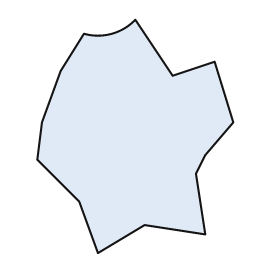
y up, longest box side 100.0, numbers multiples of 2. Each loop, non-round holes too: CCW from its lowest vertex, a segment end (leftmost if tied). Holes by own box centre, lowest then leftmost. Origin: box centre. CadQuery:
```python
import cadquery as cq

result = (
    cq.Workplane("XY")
    .moveTo(-16.0, -50.0)
    .lineTo(4.0, -38.0)
    .lineTo(30.0, -42.0)
    .lineTo(26.0, -16.0)
    .lineTo(30.0, -8.0)
    .lineTo(42.0, 6.0)
    .lineTo(34.0, 32.0)
    .lineTo(16.0, 26.0)
    .lineTo(0.0, 50.0)
    .threePointArc((-10.0, 44.0), (-22.0, 44.0))
    .lineTo(-32.0, 28.0)
    .lineTo(-40.0, 6.0)
    .lineTo(-42.0, -10.0)
    .lineTo(-24.0, -28.0)
    .close()
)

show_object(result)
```